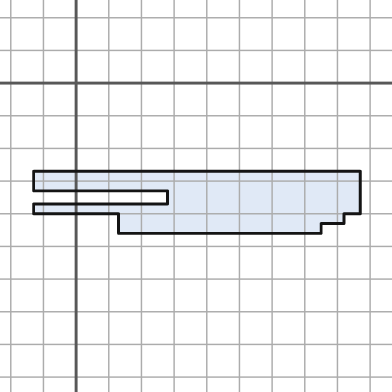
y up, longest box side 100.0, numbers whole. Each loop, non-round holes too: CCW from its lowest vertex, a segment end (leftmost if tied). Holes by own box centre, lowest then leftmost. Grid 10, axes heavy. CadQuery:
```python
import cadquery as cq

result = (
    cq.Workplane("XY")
    .moveTo(13.0, -46.0)
    .lineTo(75.0, -46.0)
    .lineTo(75.0, -43.0)
    .lineTo(82.0, -43.0)
    .lineTo(82.0, -40.0)
    .lineTo(87.0, -40.0)
    .lineTo(87.0, -27.0)
    .lineTo(-13.0, -27.0)
    .lineTo(-13.0, -33.0)
    .lineTo(28.0, -33.0)
    .lineTo(28.0, -37.0)
    .lineTo(-13.0, -37.0)
    .lineTo(-13.0, -40.0)
    .lineTo(13.0, -40.0)
    .close()
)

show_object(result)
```